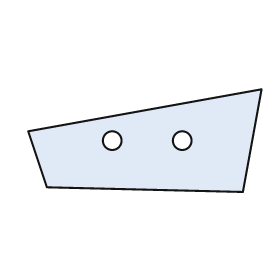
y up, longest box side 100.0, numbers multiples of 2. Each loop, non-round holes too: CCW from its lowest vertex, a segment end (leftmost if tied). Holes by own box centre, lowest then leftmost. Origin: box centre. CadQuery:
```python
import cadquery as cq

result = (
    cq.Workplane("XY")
    .moveTo(42.0, -22.0)
    .lineTo(50.0, 22.0)
    .lineTo(-50.0, 4.0)
    .lineTo(-42.0, -20.0)
    .close()
    .moveTo(-14.0, 0.0)
    .circle(4.0)
    .moveTo(16.0, 0.0)
    .circle(4.0)
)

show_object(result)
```